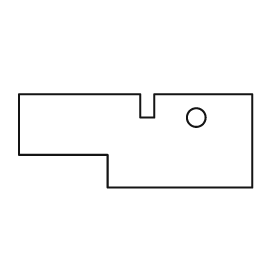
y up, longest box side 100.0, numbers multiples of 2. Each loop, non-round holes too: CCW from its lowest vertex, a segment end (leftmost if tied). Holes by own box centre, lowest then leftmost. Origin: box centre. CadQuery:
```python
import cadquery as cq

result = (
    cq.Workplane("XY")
    .moveTo(-12.0, -20.0)
    .lineTo(50.0, -20.0)
    .lineTo(50.0, 20.0)
    .lineTo(8.0, 20.0)
    .lineTo(8.0, 10.0)
    .lineTo(2.0, 10.0)
    .lineTo(2.0, 20.0)
    .lineTo(-50.0, 20.0)
    .lineTo(-50.0, -6.0)
    .lineTo(-12.0, -6.0)
    .close()
    .moveTo(26.0, 10.0)
    .circle(4.0)
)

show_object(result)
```